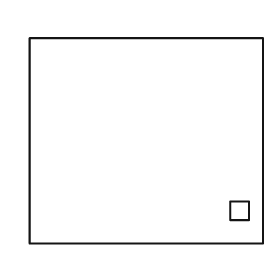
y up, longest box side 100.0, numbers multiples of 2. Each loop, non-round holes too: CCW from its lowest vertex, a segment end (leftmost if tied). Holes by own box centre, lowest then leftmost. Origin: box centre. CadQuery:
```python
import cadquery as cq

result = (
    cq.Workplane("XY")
    .moveTo(-50.0, -44.0)
    .lineTo(50.0, -44.0)
    .lineTo(50.0, 44.0)
    .lineTo(-50.0, 44.0)
    .close()
    .moveTo(36.0, -34.0)
    .lineTo(44.0, -34.0)
    .lineTo(44.0, -26.0)
    .lineTo(36.0, -26.0)
    .close()
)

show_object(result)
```